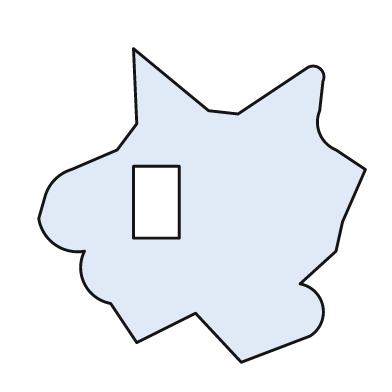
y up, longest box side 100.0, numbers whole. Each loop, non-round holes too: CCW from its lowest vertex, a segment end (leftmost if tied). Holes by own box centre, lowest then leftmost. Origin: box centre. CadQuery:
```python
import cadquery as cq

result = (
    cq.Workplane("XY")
    .moveTo(12.0, -48.0)
    .lineTo(33.0, -40.0)
    .threePointArc((37.0, -31.0), (30.0, -24.0))
    .lineTo(41.0, -14.0)
    .lineTo(43.0, -5.0)
    .lineTo(50.0, 11.0)
    .lineTo(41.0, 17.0)
    .threePointArc((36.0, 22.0), (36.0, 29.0))
    .lineTo(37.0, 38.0)
    .threePointArc((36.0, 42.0), (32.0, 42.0))
    .lineTo(11.0, 28.0)
    .lineTo(2.0, 29.0)
    .lineTo(-21.0, 48.0)
    .lineTo(-20.0, 25.0)
    .lineTo(-26.0, 17.0)
    .lineTo(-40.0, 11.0)
    .threePointArc((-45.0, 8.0), (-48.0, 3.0))
    .lineTo(-50.0, -4.0)
    .threePointArc((-45.0, -12.0), (-36.0, -14.0))
    .threePointArc((-36.0, -24.0), (-28.0, -30.0))
    .lineTo(-20.0, -42.0)
    .lineTo(-2.0, -33.0)
    .close()
    .moveTo(-21.0, -10.0)
    .lineTo(-7.0, -10.0)
    .lineTo(-7.0, 12.0)
    .lineTo(-21.0, 12.0)
    .close()
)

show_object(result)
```